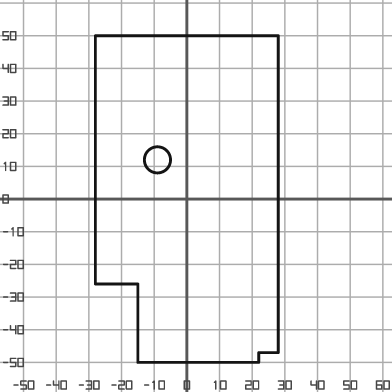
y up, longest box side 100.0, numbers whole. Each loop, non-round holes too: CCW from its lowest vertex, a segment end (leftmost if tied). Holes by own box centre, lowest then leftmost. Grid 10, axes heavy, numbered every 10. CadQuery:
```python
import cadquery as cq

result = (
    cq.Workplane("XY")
    .moveTo(-15.0, -50.0)
    .lineTo(22.0, -50.0)
    .lineTo(22.0, -47.0)
    .lineTo(28.0, -47.0)
    .lineTo(28.0, 50.0)
    .lineTo(-28.0, 50.0)
    .lineTo(-28.0, -26.0)
    .lineTo(-15.0, -26.0)
    .close()
    .moveTo(-9.0, 12.0)
    .circle(4.0)
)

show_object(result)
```